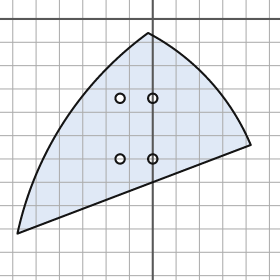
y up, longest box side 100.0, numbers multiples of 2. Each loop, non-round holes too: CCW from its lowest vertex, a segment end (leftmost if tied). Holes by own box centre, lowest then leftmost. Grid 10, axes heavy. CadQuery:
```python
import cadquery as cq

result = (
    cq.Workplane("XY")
    .moveTo(-58.0, -92.0)
    .lineTo(42.0, -54.0)
    .threePointArc((24.0, -26.0), (-2.0, -6.0))
    .threePointArc((-38.0, -44.0), (-58.0, -92.0))
    .close()
    .moveTo(-14.0, -60.0)
    .circle(2.0)
    .moveTo(0.0, -60.0)
    .circle(2.0)
    .moveTo(-14.0, -34.0)
    .circle(2.0)
    .moveTo(0.0, -34.0)
    .circle(2.0)
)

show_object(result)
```